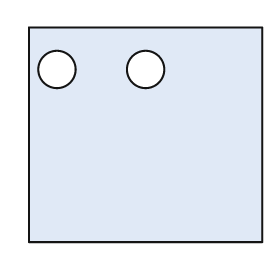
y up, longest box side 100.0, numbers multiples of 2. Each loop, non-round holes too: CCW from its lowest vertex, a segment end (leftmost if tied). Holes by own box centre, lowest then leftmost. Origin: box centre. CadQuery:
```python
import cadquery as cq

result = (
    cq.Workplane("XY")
    .moveTo(-50.0, -46.0)
    .lineTo(50.0, -46.0)
    .lineTo(50.0, 46.0)
    .lineTo(-50.0, 46.0)
    .close()
    .moveTo(-38.0, 28.0)
    .circle(8.0)
    .moveTo(0.0, 28.0)
    .circle(8.0)
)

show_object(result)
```